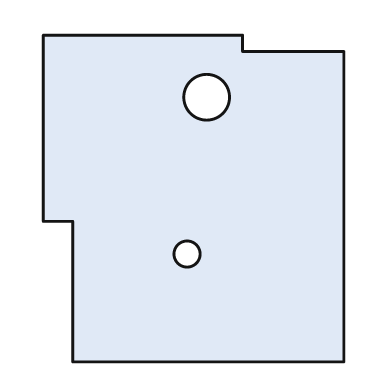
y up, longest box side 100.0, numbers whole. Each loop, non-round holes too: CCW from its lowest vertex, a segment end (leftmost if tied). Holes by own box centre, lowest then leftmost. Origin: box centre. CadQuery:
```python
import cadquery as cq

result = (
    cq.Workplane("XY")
    .moveTo(-37.0, -50.0)
    .lineTo(46.0, -50.0)
    .lineTo(46.0, 45.0)
    .lineTo(15.0, 45.0)
    .lineTo(15.0, 50.0)
    .lineTo(-46.0, 50.0)
    .lineTo(-46.0, -7.0)
    .lineTo(-37.0, -7.0)
    .close()
    .moveTo(-2.0, -17.0)
    .circle(4.0)
    .moveTo(4.0, 31.0)
    .circle(7.0)
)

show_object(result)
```